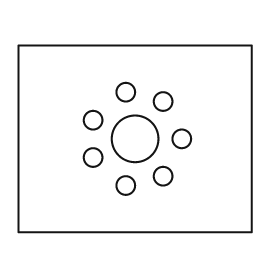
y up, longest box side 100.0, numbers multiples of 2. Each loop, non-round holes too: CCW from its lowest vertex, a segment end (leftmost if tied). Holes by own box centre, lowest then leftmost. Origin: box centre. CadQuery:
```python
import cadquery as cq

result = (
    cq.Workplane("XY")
    .moveTo(-50.0, -40.0)
    .lineTo(50.0, -40.0)
    .lineTo(50.0, 40.0)
    .lineTo(-50.0, 40.0)
    .close()
    .moveTo(-4.0, -20.0)
    .circle(4.0)
    .moveTo(12.0, -16.0)
    .circle(4.0)
    .moveTo(-18.0, -8.0)
    .circle(4.0)
    .moveTo(0.0, 0.0)
    .circle(10.0)
    .moveTo(20.0, 0.0)
    .circle(4.0)
    .moveTo(-18.0, 8.0)
    .circle(4.0)
    .moveTo(12.0, 16.0)
    .circle(4.0)
    .moveTo(-4.0, 20.0)
    .circle(4.0)
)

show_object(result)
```